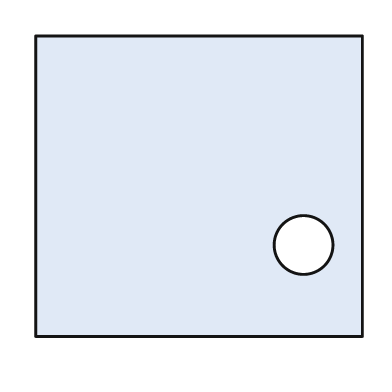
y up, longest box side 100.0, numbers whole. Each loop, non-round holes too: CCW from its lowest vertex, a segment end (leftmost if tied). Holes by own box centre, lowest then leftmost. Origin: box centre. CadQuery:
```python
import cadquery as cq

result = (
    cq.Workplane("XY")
    .moveTo(-50.0, -46.0)
    .lineTo(50.0, -46.0)
    .lineTo(50.0, 46.0)
    .lineTo(-50.0, 46.0)
    .close()
    .moveTo(32.0, -18.0)
    .circle(9.0)
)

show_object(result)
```